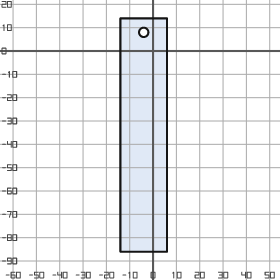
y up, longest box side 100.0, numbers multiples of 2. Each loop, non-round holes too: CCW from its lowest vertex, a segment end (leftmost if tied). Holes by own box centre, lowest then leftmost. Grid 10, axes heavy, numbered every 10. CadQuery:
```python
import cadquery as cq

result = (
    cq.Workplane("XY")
    .moveTo(-14.0, -86.0)
    .lineTo(6.0, -86.0)
    .lineTo(6.0, 14.0)
    .lineTo(-14.0, 14.0)
    .close()
    .moveTo(-4.0, 8.0)
    .circle(2.0)
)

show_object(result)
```